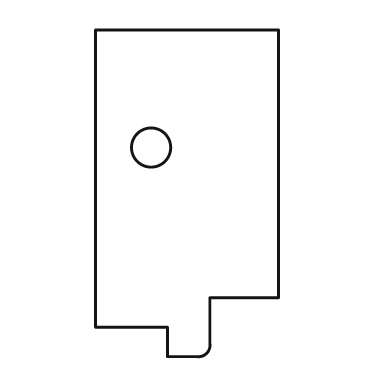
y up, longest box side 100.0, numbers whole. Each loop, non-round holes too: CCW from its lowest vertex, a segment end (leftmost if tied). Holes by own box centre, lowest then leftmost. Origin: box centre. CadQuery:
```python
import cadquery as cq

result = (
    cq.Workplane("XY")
    .moveTo(-6.0, -50.0)
    .lineTo(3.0, -50.0)
    .threePointArc((6.0, -49.0), (7.0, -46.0))
    .lineTo(7.0, -32.0)
    .lineTo(28.0, -32.0)
    .lineTo(28.0, 50.0)
    .lineTo(-28.0, 50.0)
    .lineTo(-28.0, -41.0)
    .lineTo(-6.0, -41.0)
    .close()
    .moveTo(-11.0, 14.0)
    .circle(6.0)
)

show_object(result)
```